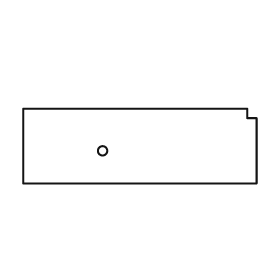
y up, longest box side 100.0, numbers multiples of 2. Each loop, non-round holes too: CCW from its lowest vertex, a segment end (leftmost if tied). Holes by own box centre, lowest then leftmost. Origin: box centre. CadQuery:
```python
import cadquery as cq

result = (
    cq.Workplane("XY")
    .moveTo(-50.0, -16.0)
    .lineTo(50.0, -16.0)
    .lineTo(50.0, 12.0)
    .lineTo(46.0, 12.0)
    .lineTo(46.0, 16.0)
    .lineTo(-50.0, 16.0)
    .close()
    .moveTo(-16.0, -2.0)
    .circle(2.0)
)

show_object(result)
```